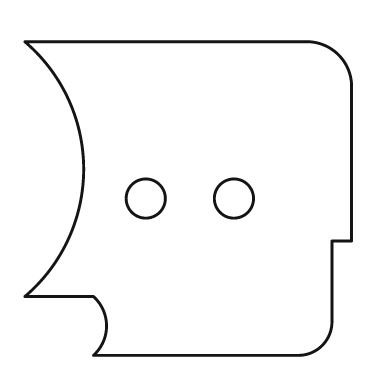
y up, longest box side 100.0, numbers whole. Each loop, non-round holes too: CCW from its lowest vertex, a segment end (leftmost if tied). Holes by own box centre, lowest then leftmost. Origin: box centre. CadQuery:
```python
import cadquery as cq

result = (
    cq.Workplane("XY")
    .moveTo(-29.0, -48.0)
    .lineTo(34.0, -48.0)
    .threePointArc((41.0, -45.0), (44.0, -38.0))
    .lineTo(44.0, -13.0)
    .lineTo(50.0, -13.0)
    .lineTo(50.0, 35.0)
    .threePointArc((46.0, 44.0), (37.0, 48.0))
    .lineTo(-50.0, 48.0)
    .threePointArc((-32.0, 9.0), (-50.0, -30.0))
    .lineTo(-29.0, -30.0)
    .threePointArc((-25.0, -39.0), (-29.0, -48.0))
    .close()
    .moveTo(-13.0, 0.0)
    .circle(6.0)
    .moveTo(14.0, 0.0)
    .circle(6.0)
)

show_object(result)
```